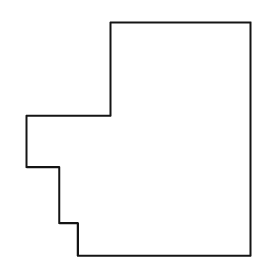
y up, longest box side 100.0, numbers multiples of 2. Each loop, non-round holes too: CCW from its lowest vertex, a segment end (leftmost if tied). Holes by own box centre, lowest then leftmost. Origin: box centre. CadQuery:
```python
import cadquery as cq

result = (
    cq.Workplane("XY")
    .moveTo(-26.0, -50.0)
    .lineTo(48.0, -50.0)
    .lineTo(48.0, 50.0)
    .lineTo(-12.0, 50.0)
    .lineTo(-12.0, 10.0)
    .lineTo(-48.0, 10.0)
    .lineTo(-48.0, -12.0)
    .lineTo(-34.0, -12.0)
    .lineTo(-34.0, -36.0)
    .lineTo(-26.0, -36.0)
    .close()
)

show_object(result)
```